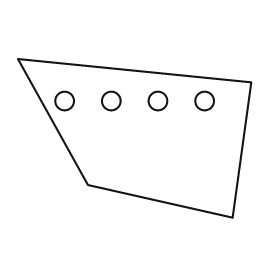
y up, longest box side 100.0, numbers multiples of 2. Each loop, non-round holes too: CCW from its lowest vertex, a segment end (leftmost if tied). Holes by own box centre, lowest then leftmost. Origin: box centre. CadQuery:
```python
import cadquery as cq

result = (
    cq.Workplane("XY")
    .moveTo(42.0, -34.0)
    .lineTo(50.0, 24.0)
    .lineTo(-50.0, 34.0)
    .lineTo(-20.0, -20.0)
    .close()
    .moveTo(-30.0, 16.0)
    .circle(4.0)
    .moveTo(-10.0, 16.0)
    .circle(4.0)
    .moveTo(10.0, 16.0)
    .circle(4.0)
    .moveTo(30.0, 16.0)
    .circle(4.0)
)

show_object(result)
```